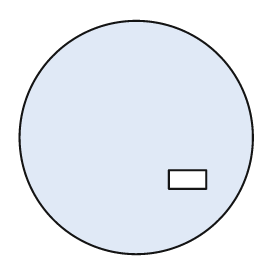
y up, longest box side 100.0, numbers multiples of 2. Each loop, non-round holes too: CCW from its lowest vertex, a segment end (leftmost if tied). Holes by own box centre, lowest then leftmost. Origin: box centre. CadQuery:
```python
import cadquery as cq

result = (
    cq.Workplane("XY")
    .moveTo(0.0, 0.0)
    .circle(50.0)
    .moveTo(14.0, -22.0)
    .lineTo(30.0, -22.0)
    .lineTo(30.0, -14.0)
    .lineTo(14.0, -14.0)
    .close()
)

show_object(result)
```